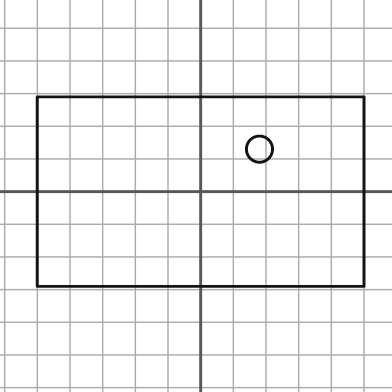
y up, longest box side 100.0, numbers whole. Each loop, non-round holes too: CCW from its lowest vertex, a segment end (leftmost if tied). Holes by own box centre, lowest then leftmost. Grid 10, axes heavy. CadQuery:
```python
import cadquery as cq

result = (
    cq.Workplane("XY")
    .moveTo(-50.0, -29.0)
    .lineTo(50.0, -29.0)
    .lineTo(50.0, 29.0)
    .lineTo(-50.0, 29.0)
    .close()
    .moveTo(18.0, 13.0)
    .circle(4.0)
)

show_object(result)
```